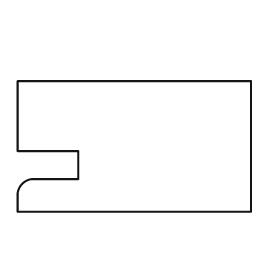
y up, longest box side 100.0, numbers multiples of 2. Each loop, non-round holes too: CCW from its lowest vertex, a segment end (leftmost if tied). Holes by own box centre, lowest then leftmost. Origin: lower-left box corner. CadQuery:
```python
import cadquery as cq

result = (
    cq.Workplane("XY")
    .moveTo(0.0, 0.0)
    .lineTo(100.0, 0.0)
    .lineTo(100.0, 56.0)
    .lineTo(0.0, 56.0)
    .lineTo(0.0, 26.0)
    .lineTo(26.0, 26.0)
    .lineTo(26.0, 14.0)
    .lineTo(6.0, 14.0)
    .threePointArc((2.0, 12.0), (0.0, 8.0))
    .close()
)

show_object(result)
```